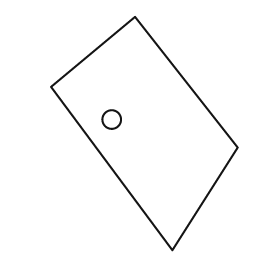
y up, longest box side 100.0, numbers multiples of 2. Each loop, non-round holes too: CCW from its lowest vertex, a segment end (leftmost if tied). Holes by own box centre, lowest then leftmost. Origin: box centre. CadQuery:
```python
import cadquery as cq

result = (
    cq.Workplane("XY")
    .moveTo(12.0, -50.0)
    .lineTo(40.0, -6.0)
    .lineTo(-4.0, 50.0)
    .lineTo(-40.0, 20.0)
    .close()
    .moveTo(-14.0, 6.0)
    .circle(4.0)
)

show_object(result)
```